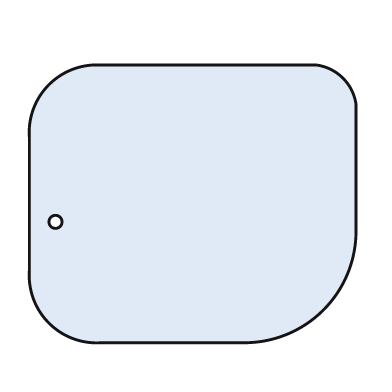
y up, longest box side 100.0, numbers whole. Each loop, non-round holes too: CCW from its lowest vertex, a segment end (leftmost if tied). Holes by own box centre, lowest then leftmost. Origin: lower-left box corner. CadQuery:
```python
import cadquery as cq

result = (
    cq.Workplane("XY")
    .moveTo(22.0, 0.0)
    .lineTo(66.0, 0.0)
    .threePointArc((90.0, 10.0), (100.0, 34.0))
    .lineTo(100.0, 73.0)
    .threePointArc((96.0, 81.0), (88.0, 85.0))
    .lineTo(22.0, 85.0)
    .threePointArc((6.0, 79.0), (0.0, 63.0))
    .lineTo(0.0, 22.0)
    .threePointArc((6.0, 6.0), (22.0, 0.0))
    .close()
    .moveTo(8.0, 37.0)
    .circle(2.0)
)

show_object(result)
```